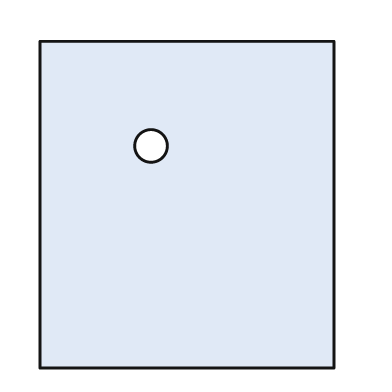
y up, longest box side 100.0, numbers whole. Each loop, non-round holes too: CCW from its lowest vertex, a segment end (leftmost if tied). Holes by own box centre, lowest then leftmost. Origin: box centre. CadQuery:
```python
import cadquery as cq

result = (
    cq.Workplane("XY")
    .moveTo(-45.0, -50.0)
    .lineTo(45.0, -50.0)
    .lineTo(45.0, 50.0)
    .lineTo(-45.0, 50.0)
    .close()
    .moveTo(-11.0, 18.0)
    .circle(5.0)
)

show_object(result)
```